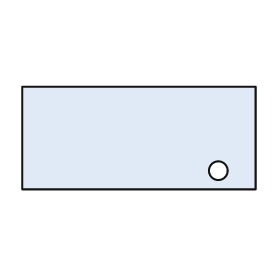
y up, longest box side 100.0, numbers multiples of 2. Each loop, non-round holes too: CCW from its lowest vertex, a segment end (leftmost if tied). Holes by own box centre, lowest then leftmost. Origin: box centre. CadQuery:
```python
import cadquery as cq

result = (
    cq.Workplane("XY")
    .moveTo(-50.0, -22.0)
    .lineTo(50.0, -22.0)
    .lineTo(50.0, 22.0)
    .lineTo(-50.0, 22.0)
    .close()
    .moveTo(34.0, -14.0)
    .circle(4.0)
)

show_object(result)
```